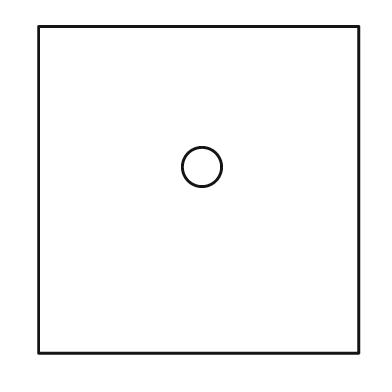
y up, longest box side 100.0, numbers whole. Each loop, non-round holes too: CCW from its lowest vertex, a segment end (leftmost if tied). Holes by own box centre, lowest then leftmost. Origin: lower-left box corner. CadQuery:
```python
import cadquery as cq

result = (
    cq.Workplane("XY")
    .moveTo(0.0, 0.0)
    .lineTo(98.0, 0.0)
    .lineTo(98.0, 100.0)
    .lineTo(0.0, 100.0)
    .close()
    .moveTo(50.0, 57.0)
    .circle(6.0)
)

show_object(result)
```